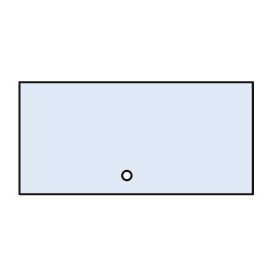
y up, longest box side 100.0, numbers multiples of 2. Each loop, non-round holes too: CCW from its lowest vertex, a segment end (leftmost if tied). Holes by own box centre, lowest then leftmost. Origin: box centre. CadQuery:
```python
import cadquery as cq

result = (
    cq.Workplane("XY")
    .moveTo(-50.0, -24.0)
    .lineTo(50.0, -24.0)
    .lineTo(50.0, 24.0)
    .lineTo(-50.0, 24.0)
    .close()
    .moveTo(-4.0, -16.0)
    .circle(2.0)
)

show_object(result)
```